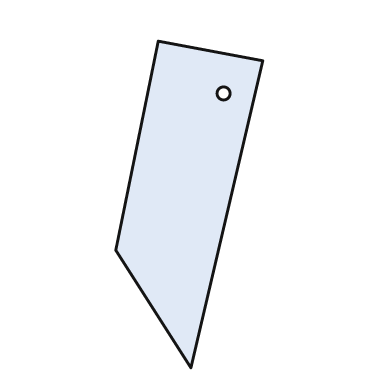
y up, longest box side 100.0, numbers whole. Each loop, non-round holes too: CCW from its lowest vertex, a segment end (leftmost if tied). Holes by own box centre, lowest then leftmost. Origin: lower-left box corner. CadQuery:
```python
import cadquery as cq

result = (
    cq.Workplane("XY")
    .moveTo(23.0, 0.0)
    .lineTo(45.0, 94.0)
    .lineTo(13.0, 100.0)
    .lineTo(0.0, 36.0)
    .close()
    .moveTo(33.0, 84.0)
    .circle(2.0)
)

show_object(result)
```